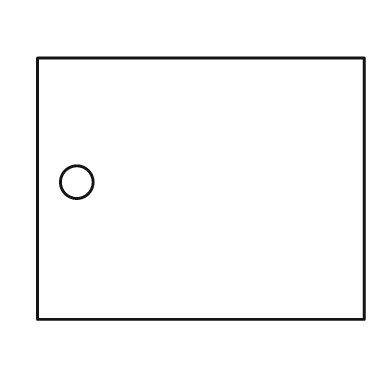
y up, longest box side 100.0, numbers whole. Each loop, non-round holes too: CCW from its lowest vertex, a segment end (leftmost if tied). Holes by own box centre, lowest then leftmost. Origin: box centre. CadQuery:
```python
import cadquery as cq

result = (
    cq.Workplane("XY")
    .moveTo(-50.0, -40.0)
    .lineTo(50.0, -40.0)
    .lineTo(50.0, 40.0)
    .lineTo(-50.0, 40.0)
    .close()
    .moveTo(-38.0, 2.0)
    .circle(5.0)
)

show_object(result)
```